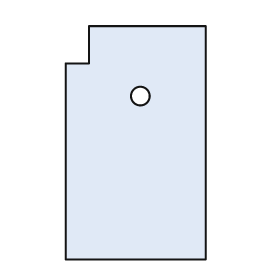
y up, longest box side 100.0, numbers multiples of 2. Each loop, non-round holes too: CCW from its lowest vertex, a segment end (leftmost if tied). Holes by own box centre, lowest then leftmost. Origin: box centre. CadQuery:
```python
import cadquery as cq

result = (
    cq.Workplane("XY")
    .moveTo(-30.0, -50.0)
    .lineTo(30.0, -50.0)
    .lineTo(30.0, 50.0)
    .lineTo(-20.0, 50.0)
    .lineTo(-20.0, 34.0)
    .lineTo(-30.0, 34.0)
    .close()
    .moveTo(2.0, 20.0)
    .circle(4.0)
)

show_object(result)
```